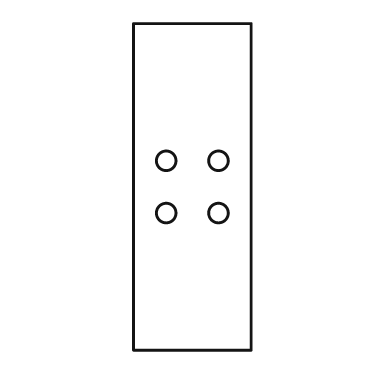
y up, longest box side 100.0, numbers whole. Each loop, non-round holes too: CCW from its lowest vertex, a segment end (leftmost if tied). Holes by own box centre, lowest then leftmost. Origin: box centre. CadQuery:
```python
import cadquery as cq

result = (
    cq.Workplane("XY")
    .moveTo(-18.0, -50.0)
    .lineTo(18.0, -50.0)
    .lineTo(18.0, 50.0)
    .lineTo(-18.0, 50.0)
    .close()
    .moveTo(-8.0, -8.0)
    .circle(3.0)
    .moveTo(8.0, -8.0)
    .circle(3.0)
    .moveTo(-8.0, 8.0)
    .circle(3.0)
    .moveTo(8.0, 8.0)
    .circle(3.0)
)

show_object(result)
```